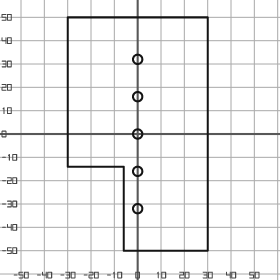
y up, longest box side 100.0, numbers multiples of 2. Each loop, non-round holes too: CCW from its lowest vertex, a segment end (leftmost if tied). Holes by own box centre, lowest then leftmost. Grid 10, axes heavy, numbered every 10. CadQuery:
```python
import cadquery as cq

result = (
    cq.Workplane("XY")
    .moveTo(-6.0, -50.0)
    .lineTo(30.0, -50.0)
    .lineTo(30.0, 50.0)
    .lineTo(-30.0, 50.0)
    .lineTo(-30.0, -14.0)
    .lineTo(-6.0, -14.0)
    .close()
    .moveTo(0.0, -32.0)
    .circle(2.0)
    .moveTo(0.0, -16.0)
    .circle(2.0)
    .moveTo(0.0, 0.0)
    .circle(2.0)
    .moveTo(0.0, 16.0)
    .circle(2.0)
    .moveTo(0.0, 32.0)
    .circle(2.0)
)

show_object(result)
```